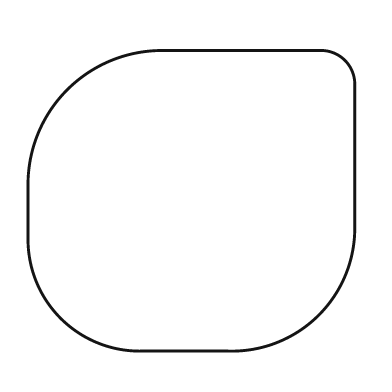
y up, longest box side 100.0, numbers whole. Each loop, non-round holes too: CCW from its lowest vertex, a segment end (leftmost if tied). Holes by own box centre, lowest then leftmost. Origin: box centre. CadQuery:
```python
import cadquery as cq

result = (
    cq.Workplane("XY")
    .moveTo(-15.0, -46.0)
    .lineTo(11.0, -46.0)
    .threePointArc((39.0, -35.0), (50.0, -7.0))
    .lineTo(50.0, 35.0)
    .threePointArc((47.0, 43.0), (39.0, 46.0))
    .lineTo(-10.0, 46.0)
    .threePointArc((-38.0, 34.0), (-50.0, 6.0))
    .lineTo(-50.0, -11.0)
    .threePointArc((-40.0, -36.0), (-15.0, -46.0))
    .close()
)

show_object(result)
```